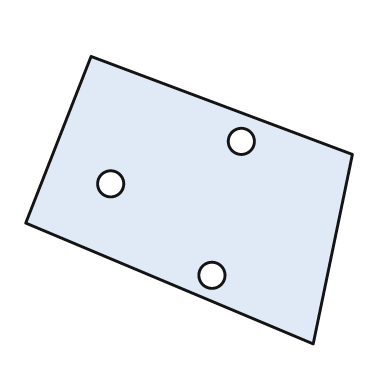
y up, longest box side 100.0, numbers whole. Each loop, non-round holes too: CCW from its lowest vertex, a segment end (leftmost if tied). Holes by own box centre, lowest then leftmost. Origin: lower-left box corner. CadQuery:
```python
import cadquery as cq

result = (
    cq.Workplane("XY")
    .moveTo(88.0, 0.0)
    .lineTo(100.0, 58.0)
    .lineTo(20.0, 88.0)
    .lineTo(0.0, 37.0)
    .close()
    .moveTo(57.0, 21.0)
    .circle(4.0)
    .moveTo(26.0, 49.0)
    .circle(4.0)
    .moveTo(66.0, 62.0)
    .circle(4.0)
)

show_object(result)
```